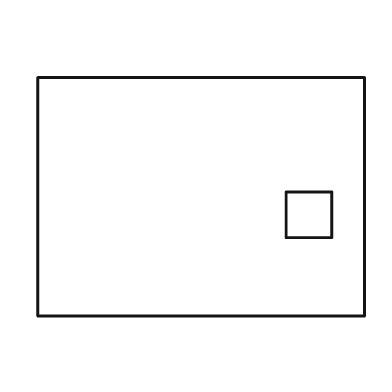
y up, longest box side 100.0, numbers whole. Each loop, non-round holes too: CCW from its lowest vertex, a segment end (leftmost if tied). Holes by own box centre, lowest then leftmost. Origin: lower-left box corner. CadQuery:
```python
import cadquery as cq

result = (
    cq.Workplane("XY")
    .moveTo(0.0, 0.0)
    .lineTo(100.0, 0.0)
    .lineTo(100.0, 73.0)
    .lineTo(0.0, 73.0)
    .close()
    .moveTo(76.0, 24.0)
    .lineTo(90.0, 24.0)
    .lineTo(90.0, 38.0)
    .lineTo(76.0, 38.0)
    .close()
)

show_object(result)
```